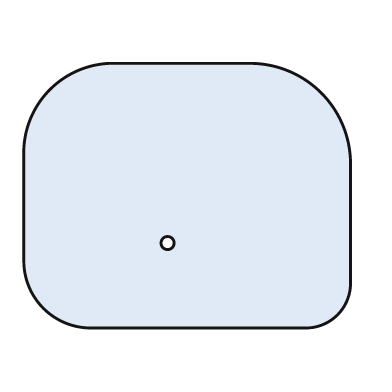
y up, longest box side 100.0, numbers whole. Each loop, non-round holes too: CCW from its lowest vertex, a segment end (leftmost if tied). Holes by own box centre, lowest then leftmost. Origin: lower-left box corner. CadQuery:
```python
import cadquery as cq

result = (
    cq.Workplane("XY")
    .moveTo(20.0, 0.0)
    .lineTo(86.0, 0.0)
    .threePointArc((96.0, 4.0), (100.0, 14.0))
    .lineTo(100.0, 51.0)
    .threePointArc((91.0, 72.0), (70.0, 81.0))
    .lineTo(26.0, 81.0)
    .threePointArc((8.0, 73.0), (0.0, 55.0))
    .lineTo(0.0, 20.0)
    .threePointArc((6.0, 6.0), (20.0, 0.0))
    .close()
    .moveTo(44.0, 26.0)
    .circle(2.0)
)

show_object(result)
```